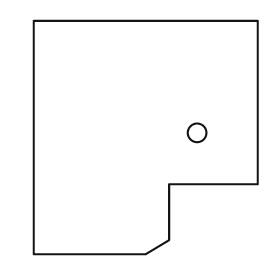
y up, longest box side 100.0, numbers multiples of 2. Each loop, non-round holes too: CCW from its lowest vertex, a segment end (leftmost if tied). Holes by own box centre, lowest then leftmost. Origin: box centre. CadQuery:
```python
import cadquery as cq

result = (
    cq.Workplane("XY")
    .moveTo(-48.0, -50.0)
    .lineTo(0.0, -50.0)
    .lineTo(10.0, -44.0)
    .lineTo(10.0, -20.0)
    .lineTo(48.0, -20.0)
    .lineTo(48.0, 50.0)
    .lineTo(-48.0, 50.0)
    .close()
    .moveTo(22.0, 2.0)
    .circle(4.0)
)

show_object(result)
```